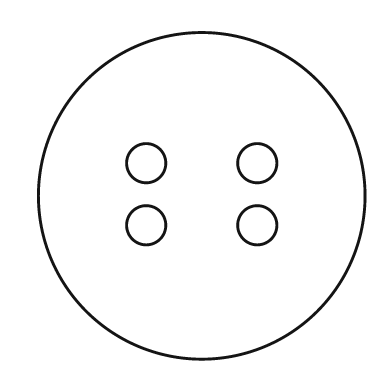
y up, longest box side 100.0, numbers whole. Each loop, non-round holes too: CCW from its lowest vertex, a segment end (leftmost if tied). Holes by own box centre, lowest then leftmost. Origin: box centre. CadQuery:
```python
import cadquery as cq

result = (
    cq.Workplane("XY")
    .moveTo(0.0, 0.0)
    .circle(50.0)
    .moveTo(-17.0, -9.0)
    .circle(6.0)
    .moveTo(17.0, -9.0)
    .circle(6.0)
    .moveTo(-17.0, 10.0)
    .circle(6.0)
    .moveTo(17.0, 10.0)
    .circle(6.0)
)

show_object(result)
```